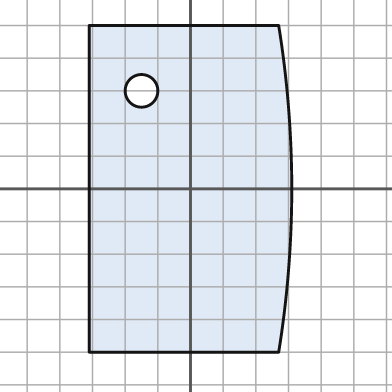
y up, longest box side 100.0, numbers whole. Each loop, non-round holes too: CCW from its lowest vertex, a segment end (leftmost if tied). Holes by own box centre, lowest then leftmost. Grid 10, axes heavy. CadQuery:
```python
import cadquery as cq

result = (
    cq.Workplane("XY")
    .moveTo(-31.0, -50.0)
    .lineTo(27.0, -50.0)
    .threePointArc((31.0, 0.0), (27.0, 50.0))
    .lineTo(-31.0, 50.0)
    .close()
    .moveTo(-15.0, 30.0)
    .circle(5.0)
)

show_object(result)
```